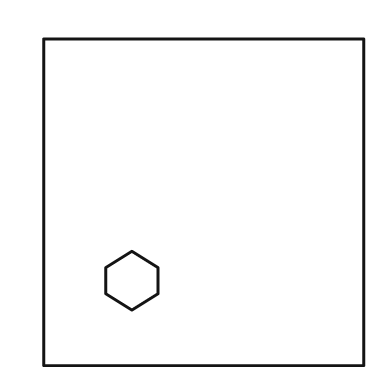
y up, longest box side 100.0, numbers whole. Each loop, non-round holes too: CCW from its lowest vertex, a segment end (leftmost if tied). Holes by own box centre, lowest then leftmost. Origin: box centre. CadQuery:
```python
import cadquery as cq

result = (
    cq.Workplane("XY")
    .moveTo(-49.0, -50.0)
    .lineTo(49.0, -50.0)
    .lineTo(49.0, 50.0)
    .lineTo(-49.0, 50.0)
    .close()
    .moveTo(-22.0, -33.0)
    .lineTo(-14.0, -28.0)
    .lineTo(-14.0, -20.0)
    .lineTo(-22.0, -15.0)
    .lineTo(-30.0, -20.0)
    .lineTo(-30.0, -28.0)
    .close()
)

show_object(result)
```